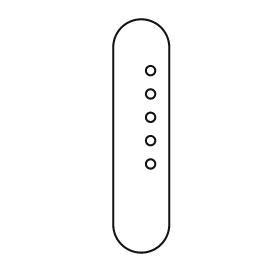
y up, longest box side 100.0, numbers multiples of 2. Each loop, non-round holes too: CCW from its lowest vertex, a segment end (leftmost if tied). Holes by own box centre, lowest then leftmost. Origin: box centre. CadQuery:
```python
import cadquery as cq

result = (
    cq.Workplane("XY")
    .moveTo(-12.0, -38.0)
    .threePointArc((0.0, -50.0), (12.0, -38.0))
    .lineTo(12.0, 38.0)
    .threePointArc((0.0, 50.0), (-12.0, 38.0))
    .close()
    .moveTo(4.0, -12.0)
    .circle(2.0)
    .moveTo(4.0, -2.0)
    .circle(2.0)
    .moveTo(4.0, 8.0)
    .circle(2.0)
    .moveTo(4.0, 18.0)
    .circle(2.0)
    .moveTo(4.0, 28.0)
    .circle(2.0)
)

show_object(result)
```